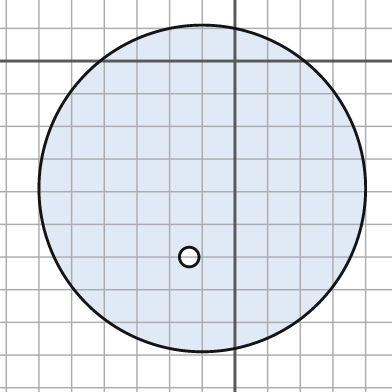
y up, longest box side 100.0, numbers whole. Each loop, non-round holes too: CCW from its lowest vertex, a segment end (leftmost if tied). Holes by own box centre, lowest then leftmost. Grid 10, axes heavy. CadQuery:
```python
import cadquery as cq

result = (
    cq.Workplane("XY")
    .moveTo(-10.0, -39.0)
    .circle(50.0)
    .moveTo(-14.0, -60.0)
    .circle(3.0)
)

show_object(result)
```